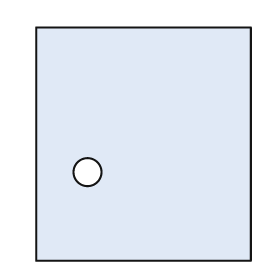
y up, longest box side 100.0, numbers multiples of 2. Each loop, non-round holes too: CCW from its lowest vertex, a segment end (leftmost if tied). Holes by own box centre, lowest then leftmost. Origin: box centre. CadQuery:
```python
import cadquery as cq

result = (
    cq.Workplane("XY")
    .moveTo(-46.0, -50.0)
    .lineTo(46.0, -50.0)
    .lineTo(46.0, 50.0)
    .lineTo(-46.0, 50.0)
    .close()
    .moveTo(-24.0, -12.0)
    .circle(6.0)
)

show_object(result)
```